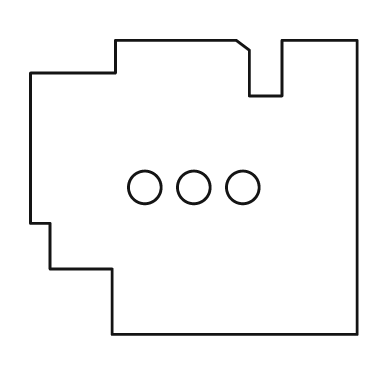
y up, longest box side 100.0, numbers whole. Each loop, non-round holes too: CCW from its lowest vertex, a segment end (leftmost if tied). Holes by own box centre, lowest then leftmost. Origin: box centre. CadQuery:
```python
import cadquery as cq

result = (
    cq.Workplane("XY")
    .moveTo(-25.0, -45.0)
    .lineTo(50.0, -45.0)
    .lineTo(50.0, 45.0)
    .lineTo(27.0, 45.0)
    .lineTo(27.0, 28.0)
    .lineTo(17.0, 28.0)
    .lineTo(17.0, 42.0)
    .lineTo(13.0, 45.0)
    .lineTo(-24.0, 45.0)
    .lineTo(-24.0, 35.0)
    .lineTo(-50.0, 35.0)
    .lineTo(-50.0, -11.0)
    .lineTo(-44.0, -11.0)
    .lineTo(-44.0, -25.0)
    .lineTo(-25.0, -25.0)
    .close()
    .moveTo(-15.0, 0.0)
    .circle(5.0)
    .moveTo(0.0, 0.0)
    .circle(5.0)
    .moveTo(15.0, 0.0)
    .circle(5.0)
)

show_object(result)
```